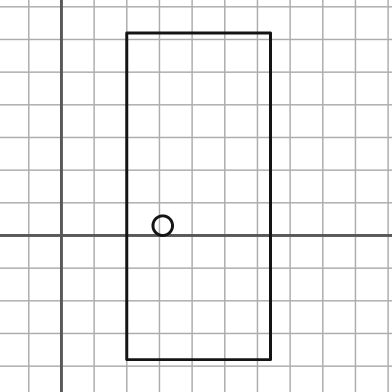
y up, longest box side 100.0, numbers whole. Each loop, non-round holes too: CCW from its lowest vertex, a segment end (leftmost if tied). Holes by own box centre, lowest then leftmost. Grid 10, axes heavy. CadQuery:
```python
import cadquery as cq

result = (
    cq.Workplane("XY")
    .moveTo(20.0, -38.0)
    .lineTo(64.0, -38.0)
    .lineTo(64.0, 62.0)
    .lineTo(20.0, 62.0)
    .close()
    .moveTo(31.0, 3.0)
    .circle(3.0)
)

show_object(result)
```